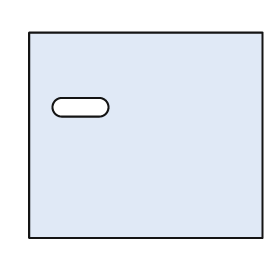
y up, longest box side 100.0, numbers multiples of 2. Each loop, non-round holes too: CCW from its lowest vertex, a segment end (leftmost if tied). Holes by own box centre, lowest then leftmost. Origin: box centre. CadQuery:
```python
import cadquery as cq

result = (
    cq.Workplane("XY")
    .moveTo(-50.0, -44.0)
    .lineTo(50.0, -44.0)
    .lineTo(50.0, 44.0)
    .lineTo(-50.0, 44.0)
    .close()
    .moveTo(-36.0, 8.0)
    .lineTo(-20.0, 8.0)
    .threePointArc((-16.0, 12.0), (-20.0, 16.0))
    .lineTo(-36.0, 16.0)
    .threePointArc((-40.0, 12.0), (-36.0, 8.0))
    .close()
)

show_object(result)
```